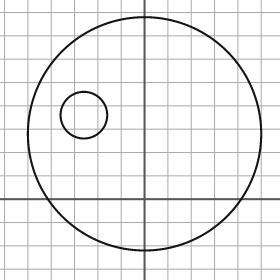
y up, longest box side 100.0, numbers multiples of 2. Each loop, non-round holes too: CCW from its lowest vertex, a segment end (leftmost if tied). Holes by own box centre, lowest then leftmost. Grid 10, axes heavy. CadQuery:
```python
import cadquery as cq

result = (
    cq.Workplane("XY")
    .moveTo(0.0, 28.0)
    .circle(50.0)
    .moveTo(-26.0, 36.0)
    .circle(10.0)
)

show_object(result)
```